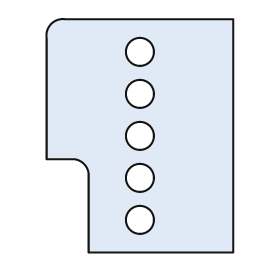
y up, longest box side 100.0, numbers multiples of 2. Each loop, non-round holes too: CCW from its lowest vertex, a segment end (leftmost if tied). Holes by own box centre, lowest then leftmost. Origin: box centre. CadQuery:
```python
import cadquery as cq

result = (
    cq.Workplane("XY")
    .moveTo(-22.0, -50.0)
    .lineTo(40.0, -50.0)
    .lineTo(40.0, 50.0)
    .lineTo(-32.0, 50.0)
    .threePointArc((-38.0, 48.0), (-40.0, 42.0))
    .lineTo(-40.0, -10.0)
    .lineTo(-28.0, -10.0)
    .threePointArc((-24.0, -12.0), (-22.0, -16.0))
    .close()
    .moveTo(0.0, -36.0)
    .circle(6.0)
    .moveTo(0.0, -18.0)
    .circle(6.0)
    .moveTo(0.0, 0.0)
    .circle(6.0)
    .moveTo(0.0, 18.0)
    .circle(6.0)
    .moveTo(0.0, 36.0)
    .circle(6.0)
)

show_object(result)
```